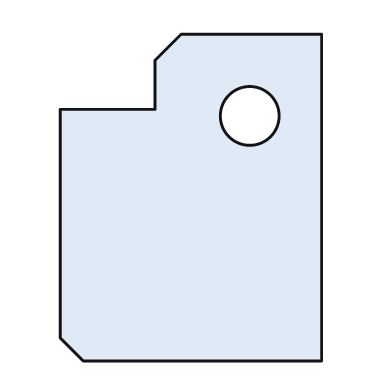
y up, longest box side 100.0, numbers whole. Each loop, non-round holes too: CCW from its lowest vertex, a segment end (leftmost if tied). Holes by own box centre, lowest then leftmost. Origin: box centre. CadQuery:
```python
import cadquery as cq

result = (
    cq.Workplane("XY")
    .moveTo(-33.0, -50.0)
    .lineTo(40.0, -50.0)
    .lineTo(40.0, 50.0)
    .lineTo(-3.0, 50.0)
    .lineTo(-11.0, 42.0)
    .lineTo(-11.0, 27.0)
    .lineTo(-40.0, 27.0)
    .lineTo(-40.0, -43.0)
    .close()
    .moveTo(18.0, 25.0)
    .circle(9.0)
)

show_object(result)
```